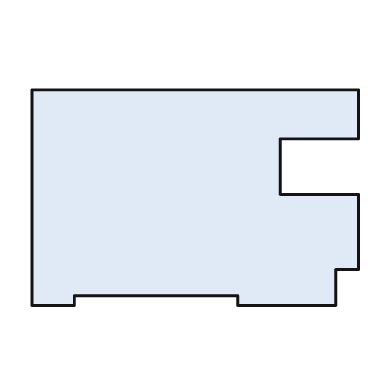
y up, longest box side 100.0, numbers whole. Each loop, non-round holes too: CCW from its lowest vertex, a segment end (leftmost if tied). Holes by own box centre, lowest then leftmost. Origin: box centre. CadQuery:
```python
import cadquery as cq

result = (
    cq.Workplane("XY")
    .moveTo(-50.0, -33.0)
    .lineTo(-37.0, -33.0)
    .lineTo(-37.0, -30.0)
    .lineTo(13.0, -30.0)
    .lineTo(13.0, -33.0)
    .lineTo(43.0, -33.0)
    .lineTo(43.0, -22.0)
    .lineTo(50.0, -22.0)
    .lineTo(50.0, 1.0)
    .lineTo(26.0, 1.0)
    .lineTo(26.0, 18.0)
    .lineTo(50.0, 18.0)
    .lineTo(50.0, 33.0)
    .lineTo(-50.0, 33.0)
    .close()
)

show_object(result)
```